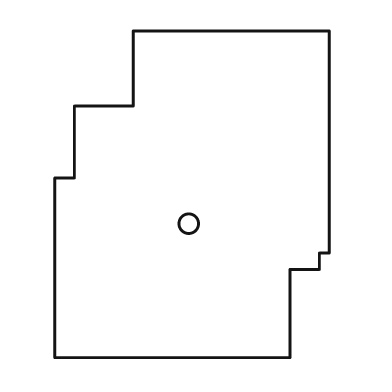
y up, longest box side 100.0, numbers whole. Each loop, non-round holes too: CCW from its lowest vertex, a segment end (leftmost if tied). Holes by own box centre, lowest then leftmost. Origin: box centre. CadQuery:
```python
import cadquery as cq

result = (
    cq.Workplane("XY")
    .moveTo(-42.0, -50.0)
    .lineTo(30.0, -50.0)
    .lineTo(30.0, -23.0)
    .lineTo(39.0, -23.0)
    .lineTo(39.0, -18.0)
    .lineTo(42.0, -18.0)
    .lineTo(42.0, 50.0)
    .lineTo(-18.0, 50.0)
    .lineTo(-18.0, 27.0)
    .lineTo(-36.0, 27.0)
    .lineTo(-36.0, 5.0)
    .lineTo(-42.0, 5.0)
    .close()
    .moveTo(-1.0, -9.0)
    .circle(3.0)
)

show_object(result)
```